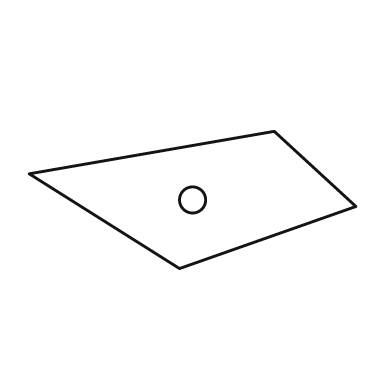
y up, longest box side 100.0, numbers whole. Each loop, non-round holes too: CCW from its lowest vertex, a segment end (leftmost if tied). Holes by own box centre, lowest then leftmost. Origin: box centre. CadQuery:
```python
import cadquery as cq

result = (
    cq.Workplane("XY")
    .moveTo(-4.0, -21.0)
    .lineTo(50.0, -2.0)
    .lineTo(25.0, 21.0)
    .lineTo(-50.0, 8.0)
    .close()
    .moveTo(0.0, 0.0)
    .circle(4.0)
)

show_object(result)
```